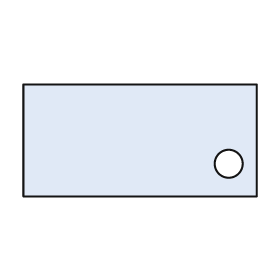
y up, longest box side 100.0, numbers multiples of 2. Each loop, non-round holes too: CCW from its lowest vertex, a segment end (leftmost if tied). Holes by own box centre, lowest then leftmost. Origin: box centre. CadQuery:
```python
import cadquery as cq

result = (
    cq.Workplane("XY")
    .moveTo(-50.0, -24.0)
    .lineTo(50.0, -24.0)
    .lineTo(50.0, 24.0)
    .lineTo(-50.0, 24.0)
    .close()
    .moveTo(38.0, -10.0)
    .circle(6.0)
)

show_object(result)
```